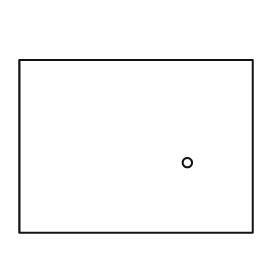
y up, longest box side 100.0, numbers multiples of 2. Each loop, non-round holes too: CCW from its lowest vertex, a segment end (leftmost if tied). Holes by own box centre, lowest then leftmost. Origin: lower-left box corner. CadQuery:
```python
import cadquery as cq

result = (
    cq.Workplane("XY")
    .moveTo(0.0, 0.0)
    .lineTo(100.0, 0.0)
    .lineTo(100.0, 74.0)
    .lineTo(0.0, 74.0)
    .close()
    .moveTo(72.0, 30.0)
    .circle(2.0)
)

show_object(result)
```